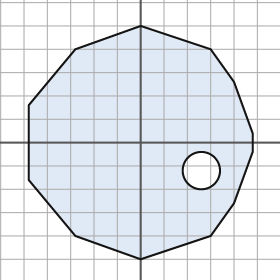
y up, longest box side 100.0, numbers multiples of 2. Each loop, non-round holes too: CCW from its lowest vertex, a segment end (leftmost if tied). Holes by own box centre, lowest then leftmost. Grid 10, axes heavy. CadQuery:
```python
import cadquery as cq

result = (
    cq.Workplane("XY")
    .moveTo(0.0, -50.0)
    .lineTo(30.0, -40.0)
    .lineTo(40.0, -26.0)
    .lineTo(48.0, -4.0)
    .lineTo(48.0, 4.0)
    .lineTo(40.0, 26.0)
    .lineTo(30.0, 40.0)
    .lineTo(0.0, 50.0)
    .lineTo(-28.0, 40.0)
    .lineTo(-48.0, 16.0)
    .lineTo(-48.0, -16.0)
    .lineTo(-28.0, -40.0)
    .close()
    .moveTo(26.0, -12.0)
    .circle(8.0)
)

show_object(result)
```